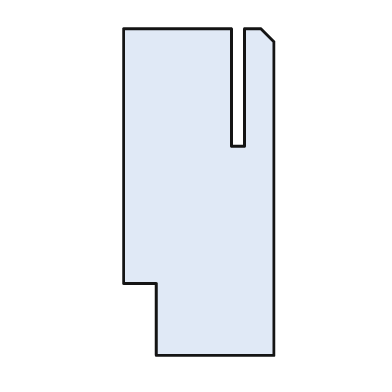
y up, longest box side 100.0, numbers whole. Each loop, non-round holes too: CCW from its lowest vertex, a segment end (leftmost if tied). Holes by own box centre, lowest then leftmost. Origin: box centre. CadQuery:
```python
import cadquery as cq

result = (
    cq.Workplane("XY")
    .moveTo(-13.0, -50.0)
    .lineTo(23.0, -50.0)
    .lineTo(23.0, 46.0)
    .lineTo(19.0, 50.0)
    .lineTo(14.0, 50.0)
    .lineTo(14.0, 14.0)
    .lineTo(10.0, 14.0)
    .lineTo(10.0, 50.0)
    .lineTo(-23.0, 50.0)
    .lineTo(-23.0, -28.0)
    .lineTo(-13.0, -28.0)
    .close()
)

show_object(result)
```